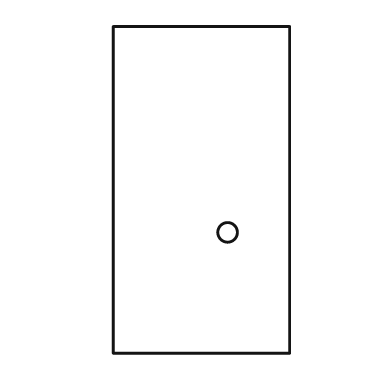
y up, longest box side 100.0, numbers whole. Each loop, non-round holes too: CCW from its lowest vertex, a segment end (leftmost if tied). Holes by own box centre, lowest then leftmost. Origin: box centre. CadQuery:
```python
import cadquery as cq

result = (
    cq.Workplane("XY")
    .moveTo(-27.0, -50.0)
    .lineTo(27.0, -50.0)
    .lineTo(27.0, 50.0)
    .lineTo(-27.0, 50.0)
    .close()
    .moveTo(8.0, -13.0)
    .circle(3.0)
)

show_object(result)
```